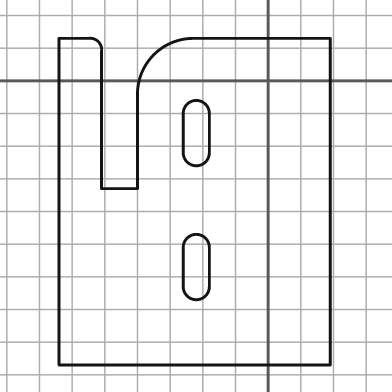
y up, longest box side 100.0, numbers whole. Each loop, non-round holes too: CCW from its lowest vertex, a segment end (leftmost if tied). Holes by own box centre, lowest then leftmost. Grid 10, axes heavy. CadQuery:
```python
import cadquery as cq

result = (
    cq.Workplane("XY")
    .moveTo(-64.0, -87.0)
    .lineTo(19.0, -87.0)
    .lineTo(19.0, 13.0)
    .lineTo(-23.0, 13.0)
    .threePointArc((-35.0, 8.0), (-40.0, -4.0))
    .lineTo(-40.0, -33.0)
    .lineTo(-51.0, -33.0)
    .lineTo(-51.0, 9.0)
    .threePointArc((-52.0, 12.0), (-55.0, 13.0))
    .lineTo(-64.0, 13.0)
    .close()
    .moveTo(-26.0, -63.0)
    .threePointArc((-22.0, -67.0), (-18.0, -63.0))
    .lineTo(-18.0, -51.0)
    .threePointArc((-22.0, -47.0), (-26.0, -51.0))
    .close()
    .moveTo(-26.0, -22.0)
    .threePointArc((-22.0, -26.0), (-18.0, -22.0))
    .lineTo(-18.0, -10.0)
    .threePointArc((-22.0, -6.0), (-26.0, -10.0))
    .close()
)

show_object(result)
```